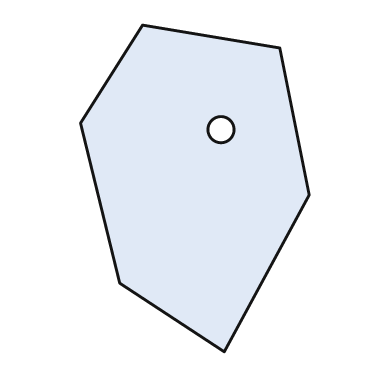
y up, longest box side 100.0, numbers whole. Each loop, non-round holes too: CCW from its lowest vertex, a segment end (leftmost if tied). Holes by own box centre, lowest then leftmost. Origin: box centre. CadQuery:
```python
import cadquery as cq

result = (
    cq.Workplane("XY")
    .moveTo(9.0, -50.0)
    .lineTo(35.0, -2.0)
    .lineTo(26.0, 43.0)
    .lineTo(-16.0, 50.0)
    .lineTo(-35.0, 20.0)
    .lineTo(-23.0, -29.0)
    .close()
    .moveTo(8.0, 18.0)
    .circle(4.0)
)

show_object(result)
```